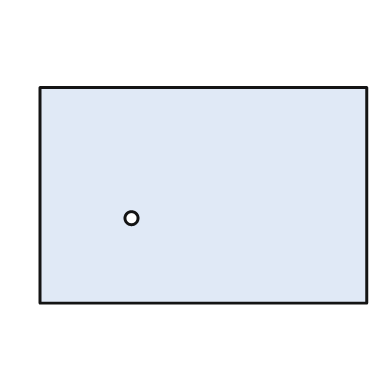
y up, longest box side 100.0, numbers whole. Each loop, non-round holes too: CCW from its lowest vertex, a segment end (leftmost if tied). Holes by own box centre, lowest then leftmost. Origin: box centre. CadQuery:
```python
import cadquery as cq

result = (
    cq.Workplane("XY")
    .moveTo(-50.0, -33.0)
    .lineTo(50.0, -33.0)
    .lineTo(50.0, 33.0)
    .lineTo(-50.0, 33.0)
    .close()
    .moveTo(-22.0, -7.0)
    .circle(2.0)
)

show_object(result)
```